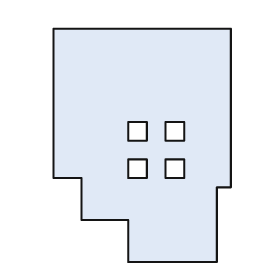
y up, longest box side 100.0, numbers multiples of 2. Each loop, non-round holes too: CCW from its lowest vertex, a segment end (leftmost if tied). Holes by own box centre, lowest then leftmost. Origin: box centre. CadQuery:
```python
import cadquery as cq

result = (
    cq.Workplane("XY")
    .moveTo(-6.0, -50.0)
    .lineTo(32.0, -50.0)
    .lineTo(32.0, -18.0)
    .lineTo(38.0, -18.0)
    .lineTo(38.0, 50.0)
    .lineTo(-38.0, 50.0)
    .lineTo(-38.0, -14.0)
    .lineTo(-26.0, -14.0)
    .lineTo(-26.0, -32.0)
    .lineTo(-6.0, -32.0)
    .close()
    .moveTo(-6.0, -14.0)
    .lineTo(2.0, -14.0)
    .lineTo(2.0, -6.0)
    .lineTo(-6.0, -6.0)
    .close()
    .moveTo(10.0, -14.0)
    .lineTo(18.0, -14.0)
    .lineTo(18.0, -6.0)
    .lineTo(10.0, -6.0)
    .close()
    .moveTo(-6.0, 2.0)
    .lineTo(2.0, 2.0)
    .lineTo(2.0, 10.0)
    .lineTo(-6.0, 10.0)
    .close()
    .moveTo(10.0, 2.0)
    .lineTo(18.0, 2.0)
    .lineTo(18.0, 10.0)
    .lineTo(10.0, 10.0)
    .close()
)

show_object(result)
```